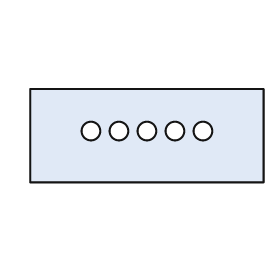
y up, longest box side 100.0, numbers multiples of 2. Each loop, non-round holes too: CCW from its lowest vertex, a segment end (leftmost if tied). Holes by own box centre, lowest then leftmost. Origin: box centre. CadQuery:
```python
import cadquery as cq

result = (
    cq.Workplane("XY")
    .moveTo(-50.0, -20.0)
    .lineTo(50.0, -20.0)
    .lineTo(50.0, 20.0)
    .lineTo(-50.0, 20.0)
    .close()
    .moveTo(-24.0, 2.0)
    .circle(4.0)
    .moveTo(-12.0, 2.0)
    .circle(4.0)
    .moveTo(0.0, 2.0)
    .circle(4.0)
    .moveTo(12.0, 2.0)
    .circle(4.0)
    .moveTo(24.0, 2.0)
    .circle(4.0)
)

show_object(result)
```